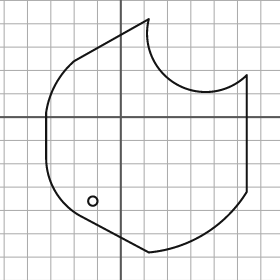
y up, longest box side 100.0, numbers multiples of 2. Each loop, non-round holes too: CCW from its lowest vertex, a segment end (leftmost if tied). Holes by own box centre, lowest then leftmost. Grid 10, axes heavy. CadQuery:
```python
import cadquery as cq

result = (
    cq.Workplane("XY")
    .moveTo(12.0, -58.0)
    .threePointArc((36.0, -50.0), (54.0, -32.0))
    .lineTo(54.0, 18.0)
    .threePointArc((24.0, 14.0), (12.0, 42.0))
    .lineTo(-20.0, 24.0)
    .threePointArc((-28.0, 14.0), (-32.0, 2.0))
    .lineTo(-32.0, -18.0)
    .threePointArc((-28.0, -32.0), (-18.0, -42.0))
    .close()
    .moveTo(-12.0, -36.0)
    .circle(2.0)
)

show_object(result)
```